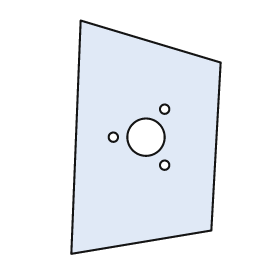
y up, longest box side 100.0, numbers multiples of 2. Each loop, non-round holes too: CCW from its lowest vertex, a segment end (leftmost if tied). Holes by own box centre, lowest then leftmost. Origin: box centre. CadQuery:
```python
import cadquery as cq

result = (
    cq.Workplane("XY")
    .moveTo(-32.0, -50.0)
    .lineTo(28.0, -40.0)
    .lineTo(32.0, 32.0)
    .lineTo(-28.0, 50.0)
    .close()
    .moveTo(8.0, -12.0)
    .circle(2.0)
    .moveTo(-14.0, 0.0)
    .circle(2.0)
    .moveTo(0.0, 0.0)
    .circle(8.0)
    .moveTo(8.0, 12.0)
    .circle(2.0)
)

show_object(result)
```